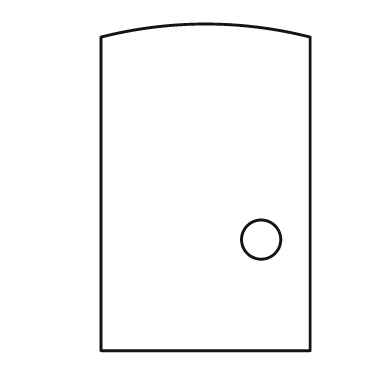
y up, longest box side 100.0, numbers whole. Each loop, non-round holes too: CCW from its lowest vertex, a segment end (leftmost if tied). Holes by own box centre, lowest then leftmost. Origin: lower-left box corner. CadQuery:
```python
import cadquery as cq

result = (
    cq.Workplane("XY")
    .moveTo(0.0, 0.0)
    .lineTo(64.0, 0.0)
    .lineTo(64.0, 96.0)
    .threePointArc((32.0, 100.0), (0.0, 96.0))
    .close()
    .moveTo(49.0, 34.0)
    .circle(6.0)
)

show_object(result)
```